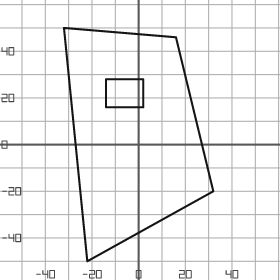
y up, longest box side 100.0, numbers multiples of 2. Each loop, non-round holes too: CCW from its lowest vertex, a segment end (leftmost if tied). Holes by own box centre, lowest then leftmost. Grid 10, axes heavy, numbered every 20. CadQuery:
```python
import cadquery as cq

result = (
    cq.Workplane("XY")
    .moveTo(-22.0, -50.0)
    .lineTo(32.0, -20.0)
    .lineTo(16.0, 46.0)
    .lineTo(-32.0, 50.0)
    .close()
    .moveTo(-14.0, 16.0)
    .lineTo(2.0, 16.0)
    .lineTo(2.0, 28.0)
    .lineTo(-14.0, 28.0)
    .close()
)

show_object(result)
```